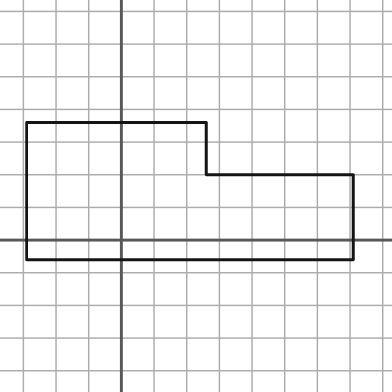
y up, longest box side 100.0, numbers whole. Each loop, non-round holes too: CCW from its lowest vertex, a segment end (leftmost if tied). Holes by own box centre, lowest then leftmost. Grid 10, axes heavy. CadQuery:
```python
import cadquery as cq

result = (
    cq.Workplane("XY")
    .moveTo(-29.0, -6.0)
    .lineTo(71.0, -6.0)
    .lineTo(71.0, 20.0)
    .lineTo(26.0, 20.0)
    .lineTo(26.0, 36.0)
    .lineTo(-29.0, 36.0)
    .close()
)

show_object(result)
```